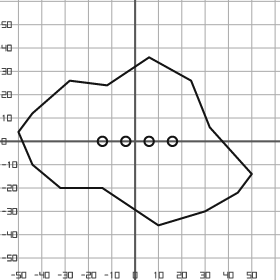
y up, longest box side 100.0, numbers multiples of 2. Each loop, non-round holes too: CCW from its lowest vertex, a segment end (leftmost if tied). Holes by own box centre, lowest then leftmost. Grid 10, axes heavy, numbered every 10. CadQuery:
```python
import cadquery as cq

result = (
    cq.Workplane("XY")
    .moveTo(10.0, -36.0)
    .lineTo(30.0, -30.0)
    .lineTo(44.0, -22.0)
    .lineTo(50.0, -14.0)
    .lineTo(32.0, 6.0)
    .lineTo(24.0, 26.0)
    .lineTo(6.0, 36.0)
    .lineTo(-12.0, 24.0)
    .lineTo(-28.0, 26.0)
    .lineTo(-44.0, 12.0)
    .lineTo(-50.0, 4.0)
    .lineTo(-44.0, -10.0)
    .lineTo(-32.0, -20.0)
    .lineTo(-14.0, -20.0)
    .close()
    .moveTo(-14.0, 0.0)
    .circle(2.0)
    .moveTo(-4.0, 0.0)
    .circle(2.0)
    .moveTo(6.0, 0.0)
    .circle(2.0)
    .moveTo(16.0, 0.0)
    .circle(2.0)
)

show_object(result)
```